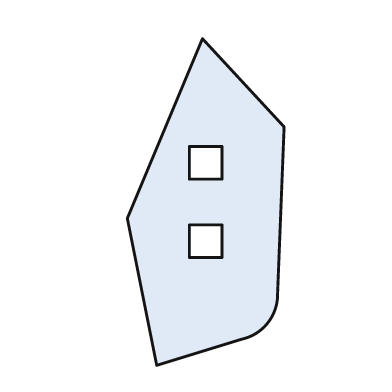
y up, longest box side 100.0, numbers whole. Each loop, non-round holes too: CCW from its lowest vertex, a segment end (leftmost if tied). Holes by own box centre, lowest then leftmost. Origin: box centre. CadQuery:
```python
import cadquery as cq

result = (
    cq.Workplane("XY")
    .moveTo(-15.0, -50.0)
    .lineTo(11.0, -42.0)
    .threePointArc((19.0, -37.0), (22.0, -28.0))
    .lineTo(24.0, 23.0)
    .lineTo(-1.0, 50.0)
    .lineTo(-24.0, -5.0)
    .close()
    .moveTo(-5.0, -17.0)
    .lineTo(5.0, -17.0)
    .lineTo(5.0, -7.0)
    .lineTo(-5.0, -7.0)
    .close()
    .moveTo(-5.0, 7.0)
    .lineTo(5.0, 7.0)
    .lineTo(5.0, 17.0)
    .lineTo(-5.0, 17.0)
    .close()
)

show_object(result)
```